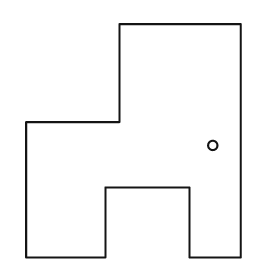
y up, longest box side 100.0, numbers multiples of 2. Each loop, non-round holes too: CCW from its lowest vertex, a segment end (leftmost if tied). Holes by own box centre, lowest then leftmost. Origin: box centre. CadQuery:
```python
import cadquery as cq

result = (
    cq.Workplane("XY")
    .moveTo(-46.0, -50.0)
    .lineTo(-12.0, -50.0)
    .lineTo(-12.0, -20.0)
    .lineTo(24.0, -20.0)
    .lineTo(24.0, -50.0)
    .lineTo(46.0, -50.0)
    .lineTo(46.0, 50.0)
    .lineTo(-6.0, 50.0)
    .lineTo(-6.0, 8.0)
    .lineTo(-46.0, 8.0)
    .close()
    .moveTo(34.0, -2.0)
    .circle(2.0)
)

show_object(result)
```